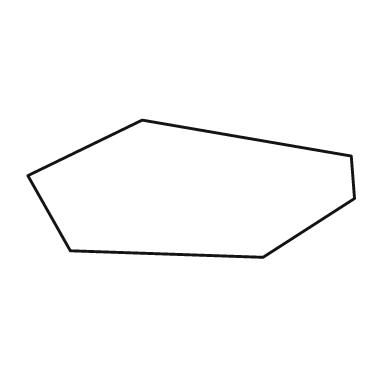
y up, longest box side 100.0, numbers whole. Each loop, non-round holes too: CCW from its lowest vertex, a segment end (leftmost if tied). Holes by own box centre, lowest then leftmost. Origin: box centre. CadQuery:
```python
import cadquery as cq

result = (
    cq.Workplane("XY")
    .moveTo(22.0, -21.0)
    .lineTo(50.0, -3.0)
    .lineTo(49.0, 10.0)
    .lineTo(-15.0, 21.0)
    .lineTo(-50.0, 4.0)
    .lineTo(-37.0, -19.0)
    .close()
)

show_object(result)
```